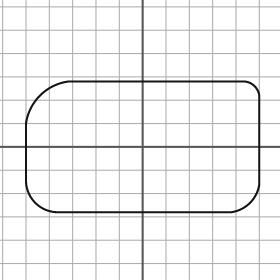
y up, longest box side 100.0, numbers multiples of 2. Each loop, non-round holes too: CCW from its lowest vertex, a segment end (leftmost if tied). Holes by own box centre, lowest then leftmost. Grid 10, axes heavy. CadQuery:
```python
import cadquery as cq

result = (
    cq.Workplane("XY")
    .moveTo(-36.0, -28.0)
    .lineTo(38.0, -28.0)
    .threePointArc((46.0, -24.0), (50.0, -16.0))
    .lineTo(50.0, 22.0)
    .threePointArc((48.0, 26.0), (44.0, 28.0))
    .lineTo(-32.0, 28.0)
    .threePointArc((-44.0, 22.0), (-50.0, 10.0))
    .lineTo(-50.0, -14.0)
    .threePointArc((-46.0, -24.0), (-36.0, -28.0))
    .close()
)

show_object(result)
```